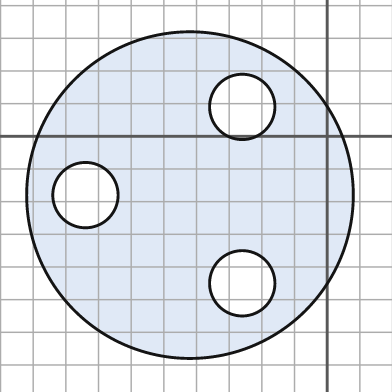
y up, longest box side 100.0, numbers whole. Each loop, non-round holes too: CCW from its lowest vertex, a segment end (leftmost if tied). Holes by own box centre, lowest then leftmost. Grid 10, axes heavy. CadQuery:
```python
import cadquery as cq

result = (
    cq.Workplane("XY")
    .moveTo(-42.0, -18.0)
    .circle(50.0)
    .moveTo(-26.0, -45.0)
    .circle(10.0)
    .moveTo(-74.0, -18.0)
    .circle(10.0)
    .moveTo(-26.0, 9.0)
    .circle(10.0)
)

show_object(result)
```